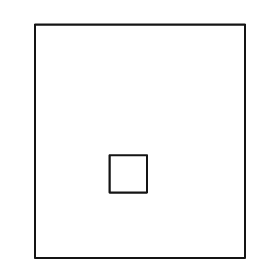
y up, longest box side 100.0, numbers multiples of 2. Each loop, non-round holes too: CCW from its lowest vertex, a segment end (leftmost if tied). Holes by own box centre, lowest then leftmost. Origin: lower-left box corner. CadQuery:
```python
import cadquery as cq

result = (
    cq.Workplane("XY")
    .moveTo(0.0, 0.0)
    .lineTo(90.0, 0.0)
    .lineTo(90.0, 100.0)
    .lineTo(0.0, 100.0)
    .close()
    .moveTo(32.0, 28.0)
    .lineTo(48.0, 28.0)
    .lineTo(48.0, 44.0)
    .lineTo(32.0, 44.0)
    .close()
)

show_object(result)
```